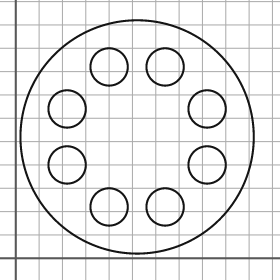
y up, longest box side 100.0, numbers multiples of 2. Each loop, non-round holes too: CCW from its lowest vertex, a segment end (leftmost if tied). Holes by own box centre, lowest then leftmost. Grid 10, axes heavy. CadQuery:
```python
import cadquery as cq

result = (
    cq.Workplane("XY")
    .moveTo(52.0, 52.0)
    .circle(50.0)
    .moveTo(40.0, 22.0)
    .circle(8.0)
    .moveTo(64.0, 22.0)
    .circle(8.0)
    .moveTo(22.0, 40.0)
    .circle(8.0)
    .moveTo(82.0, 40.0)
    .circle(8.0)
    .moveTo(22.0, 64.0)
    .circle(8.0)
    .moveTo(82.0, 64.0)
    .circle(8.0)
    .moveTo(40.0, 82.0)
    .circle(8.0)
    .moveTo(64.0, 82.0)
    .circle(8.0)
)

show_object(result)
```